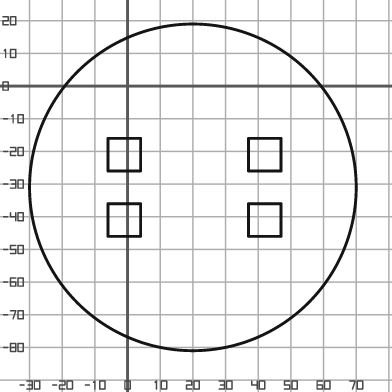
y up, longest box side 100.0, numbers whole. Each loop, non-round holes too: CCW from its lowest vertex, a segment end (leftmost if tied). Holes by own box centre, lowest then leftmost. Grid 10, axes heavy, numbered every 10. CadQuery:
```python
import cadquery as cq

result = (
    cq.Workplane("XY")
    .moveTo(20.0, -31.0)
    .circle(50.0)
    .moveTo(-6.0, -46.0)
    .lineTo(4.0, -46.0)
    .lineTo(4.0, -36.0)
    .lineTo(-6.0, -36.0)
    .close()
    .moveTo(37.0, -46.0)
    .lineTo(47.0, -46.0)
    .lineTo(47.0, -36.0)
    .lineTo(37.0, -36.0)
    .close()
    .moveTo(-6.0, -26.0)
    .lineTo(4.0, -26.0)
    .lineTo(4.0, -16.0)
    .lineTo(-6.0, -16.0)
    .close()
    .moveTo(37.0, -26.0)
    .lineTo(47.0, -26.0)
    .lineTo(47.0, -16.0)
    .lineTo(37.0, -16.0)
    .close()
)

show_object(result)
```